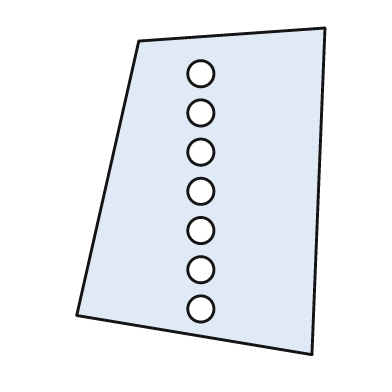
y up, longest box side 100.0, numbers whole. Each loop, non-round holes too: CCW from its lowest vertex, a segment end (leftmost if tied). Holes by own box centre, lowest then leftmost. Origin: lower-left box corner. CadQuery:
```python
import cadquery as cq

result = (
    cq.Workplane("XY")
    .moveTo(72.0, 0.0)
    .lineTo(76.0, 100.0)
    .lineTo(19.0, 96.0)
    .lineTo(0.0, 12.0)
    .close()
    .moveTo(38.0, 14.0)
    .circle(4.0)
    .moveTo(38.0, 26.0)
    .circle(4.0)
    .moveTo(38.0, 38.0)
    .circle(4.0)
    .moveTo(38.0, 50.0)
    .circle(4.0)
    .moveTo(38.0, 62.0)
    .circle(4.0)
    .moveTo(38.0, 74.0)
    .circle(4.0)
    .moveTo(38.0, 86.0)
    .circle(4.0)
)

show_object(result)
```